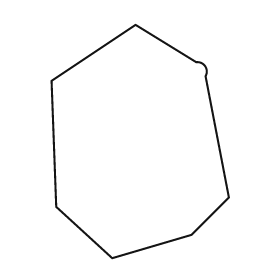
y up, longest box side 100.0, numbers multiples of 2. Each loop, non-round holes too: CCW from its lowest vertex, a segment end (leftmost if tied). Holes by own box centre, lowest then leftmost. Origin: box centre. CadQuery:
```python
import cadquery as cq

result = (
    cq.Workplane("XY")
    .moveTo(-12.0, -50.0)
    .lineTo(22.0, -40.0)
    .lineTo(38.0, -24.0)
    .lineTo(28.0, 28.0)
    .threePointArc((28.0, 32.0), (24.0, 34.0))
    .lineTo(-2.0, 50.0)
    .lineTo(-38.0, 26.0)
    .lineTo(-36.0, -28.0)
    .close()
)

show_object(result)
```